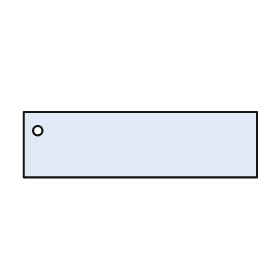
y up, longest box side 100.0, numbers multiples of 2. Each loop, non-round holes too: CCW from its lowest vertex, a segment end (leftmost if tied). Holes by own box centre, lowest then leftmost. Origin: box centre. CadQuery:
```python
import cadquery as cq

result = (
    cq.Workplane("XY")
    .moveTo(-50.0, -14.0)
    .lineTo(50.0, -14.0)
    .lineTo(50.0, 14.0)
    .lineTo(-50.0, 14.0)
    .close()
    .moveTo(-44.0, 6.0)
    .circle(2.0)
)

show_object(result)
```